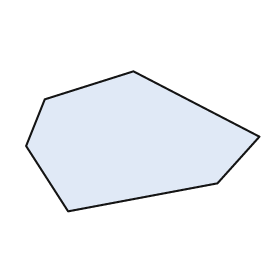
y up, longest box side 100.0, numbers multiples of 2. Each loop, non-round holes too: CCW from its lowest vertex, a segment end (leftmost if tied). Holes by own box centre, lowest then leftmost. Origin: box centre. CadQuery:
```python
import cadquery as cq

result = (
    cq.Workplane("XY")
    .moveTo(-32.0, -30.0)
    .lineTo(32.0, -18.0)
    .lineTo(50.0, 2.0)
    .lineTo(-4.0, 30.0)
    .lineTo(-42.0, 18.0)
    .lineTo(-50.0, -2.0)
    .close()
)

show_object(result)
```